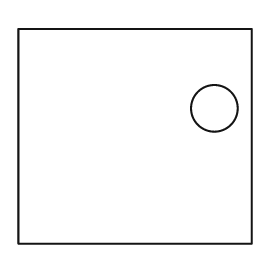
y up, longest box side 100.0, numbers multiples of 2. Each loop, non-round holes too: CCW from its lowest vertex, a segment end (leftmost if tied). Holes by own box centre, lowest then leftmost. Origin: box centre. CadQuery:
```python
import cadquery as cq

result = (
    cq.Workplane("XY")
    .moveTo(-50.0, -46.0)
    .lineTo(50.0, -46.0)
    .lineTo(50.0, 46.0)
    .lineTo(-50.0, 46.0)
    .close()
    .moveTo(34.0, 12.0)
    .circle(10.0)
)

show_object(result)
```